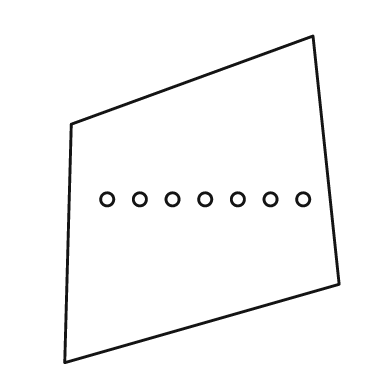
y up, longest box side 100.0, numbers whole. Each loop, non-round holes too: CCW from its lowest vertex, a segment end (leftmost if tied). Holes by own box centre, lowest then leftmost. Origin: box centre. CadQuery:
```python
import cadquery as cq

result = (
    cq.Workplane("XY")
    .moveTo(-42.0, -50.0)
    .lineTo(42.0, -26.0)
    .lineTo(34.0, 50.0)
    .lineTo(-40.0, 23.0)
    .close()
    .moveTo(-29.0, 0.0)
    .circle(2.0)
    .moveTo(-19.0, 0.0)
    .circle(2.0)
    .moveTo(-9.0, 0.0)
    .circle(2.0)
    .moveTo(1.0, 0.0)
    .circle(2.0)
    .moveTo(11.0, 0.0)
    .circle(2.0)
    .moveTo(21.0, 0.0)
    .circle(2.0)
    .moveTo(31.0, 0.0)
    .circle(2.0)
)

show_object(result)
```